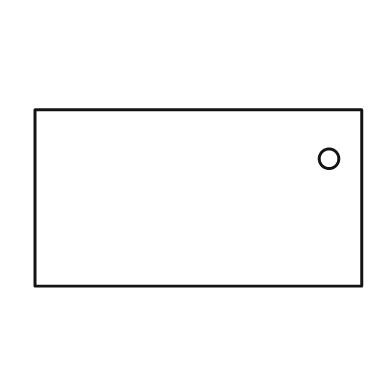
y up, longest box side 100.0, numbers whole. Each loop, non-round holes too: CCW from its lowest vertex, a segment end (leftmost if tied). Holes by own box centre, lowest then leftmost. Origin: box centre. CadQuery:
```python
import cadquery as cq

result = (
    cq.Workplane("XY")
    .moveTo(-50.0, -27.0)
    .lineTo(50.0, -27.0)
    .lineTo(50.0, 27.0)
    .lineTo(-50.0, 27.0)
    .close()
    .moveTo(40.0, 12.0)
    .circle(3.0)
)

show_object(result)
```